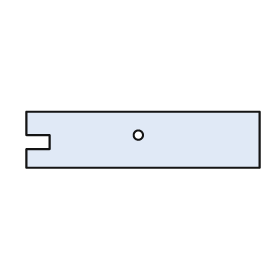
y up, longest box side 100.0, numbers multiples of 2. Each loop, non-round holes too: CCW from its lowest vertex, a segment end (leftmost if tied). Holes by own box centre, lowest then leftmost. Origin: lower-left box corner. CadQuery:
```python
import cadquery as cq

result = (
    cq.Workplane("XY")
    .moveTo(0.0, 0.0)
    .lineTo(100.0, 0.0)
    .lineTo(100.0, 24.0)
    .lineTo(0.0, 24.0)
    .lineTo(0.0, 14.0)
    .lineTo(10.0, 14.0)
    .lineTo(10.0, 8.0)
    .lineTo(0.0, 8.0)
    .close()
    .moveTo(48.0, 14.0)
    .circle(2.0)
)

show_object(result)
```